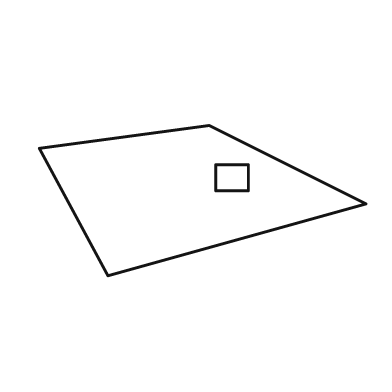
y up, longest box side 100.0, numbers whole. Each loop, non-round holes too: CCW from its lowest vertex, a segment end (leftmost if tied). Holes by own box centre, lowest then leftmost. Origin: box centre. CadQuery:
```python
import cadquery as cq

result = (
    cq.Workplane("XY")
    .moveTo(-29.0, -23.0)
    .lineTo(50.0, -1.0)
    .lineTo(2.0, 23.0)
    .lineTo(-50.0, 16.0)
    .close()
    .moveTo(4.0, 3.0)
    .lineTo(14.0, 3.0)
    .lineTo(14.0, 11.0)
    .lineTo(4.0, 11.0)
    .close()
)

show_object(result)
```